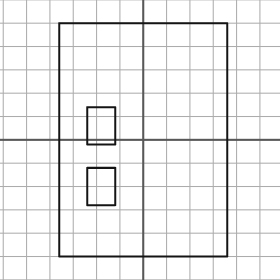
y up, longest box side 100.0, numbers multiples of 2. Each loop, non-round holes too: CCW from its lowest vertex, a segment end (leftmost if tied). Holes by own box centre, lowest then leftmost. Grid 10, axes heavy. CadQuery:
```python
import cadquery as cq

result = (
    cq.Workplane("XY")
    .moveTo(-36.0, -50.0)
    .lineTo(36.0, -50.0)
    .lineTo(36.0, 50.0)
    .lineTo(-36.0, 50.0)
    .close()
    .moveTo(-24.0, -28.0)
    .lineTo(-12.0, -28.0)
    .lineTo(-12.0, -12.0)
    .lineTo(-24.0, -12.0)
    .close()
    .moveTo(-24.0, -2.0)
    .lineTo(-12.0, -2.0)
    .lineTo(-12.0, 14.0)
    .lineTo(-24.0, 14.0)
    .close()
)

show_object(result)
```